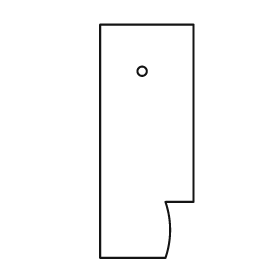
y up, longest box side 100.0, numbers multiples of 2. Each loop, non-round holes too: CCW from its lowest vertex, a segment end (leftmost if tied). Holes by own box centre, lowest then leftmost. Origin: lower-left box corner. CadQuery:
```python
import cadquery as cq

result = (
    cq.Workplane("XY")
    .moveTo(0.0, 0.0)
    .lineTo(28.0, 0.0)
    .threePointArc((30.0, 12.0), (28.0, 24.0))
    .lineTo(40.0, 24.0)
    .lineTo(40.0, 100.0)
    .lineTo(0.0, 100.0)
    .close()
    .moveTo(18.0, 80.0)
    .circle(2.0)
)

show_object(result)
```